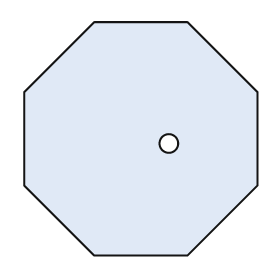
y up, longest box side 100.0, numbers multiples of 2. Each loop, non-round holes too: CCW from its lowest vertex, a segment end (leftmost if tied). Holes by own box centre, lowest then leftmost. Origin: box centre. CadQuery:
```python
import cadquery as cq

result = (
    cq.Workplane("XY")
    .moveTo(-20.0, -50.0)
    .lineTo(20.0, -50.0)
    .lineTo(50.0, -20.0)
    .lineTo(50.0, 20.0)
    .lineTo(20.0, 50.0)
    .lineTo(-20.0, 50.0)
    .lineTo(-50.0, 20.0)
    .lineTo(-50.0, -20.0)
    .close()
    .moveTo(12.0, -2.0)
    .circle(4.0)
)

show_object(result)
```